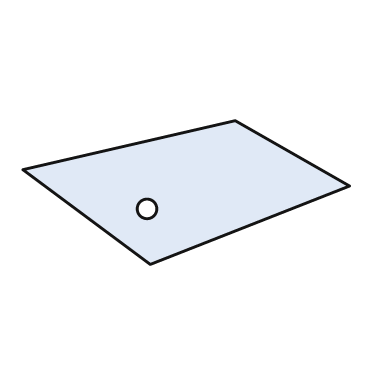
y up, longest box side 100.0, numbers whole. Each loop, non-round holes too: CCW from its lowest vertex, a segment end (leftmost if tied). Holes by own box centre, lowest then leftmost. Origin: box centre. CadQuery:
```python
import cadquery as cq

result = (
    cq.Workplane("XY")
    .moveTo(-11.0, -22.0)
    .lineTo(50.0, 2.0)
    .lineTo(15.0, 22.0)
    .lineTo(-50.0, 7.0)
    .close()
    .moveTo(-12.0, -5.0)
    .circle(3.0)
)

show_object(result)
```